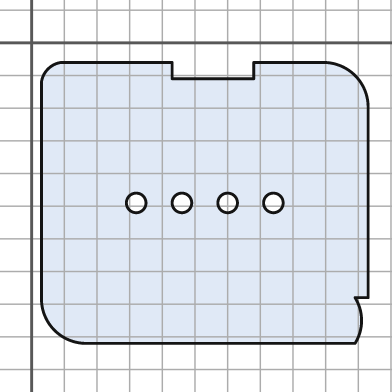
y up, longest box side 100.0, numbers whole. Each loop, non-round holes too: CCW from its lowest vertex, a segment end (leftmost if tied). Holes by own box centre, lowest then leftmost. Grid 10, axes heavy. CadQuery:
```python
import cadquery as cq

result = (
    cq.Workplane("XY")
    .moveTo(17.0, -92.0)
    .lineTo(99.0, -92.0)
    .threePointArc((101.0, -85.0), (99.0, -78.0))
    .lineTo(103.0, -78.0)
    .lineTo(103.0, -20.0)
    .threePointArc((99.0, -10.0), (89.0, -6.0))
    .lineTo(68.0, -6.0)
    .lineTo(68.0, -11.0)
    .lineTo(43.0, -11.0)
    .lineTo(43.0, -6.0)
    .lineTo(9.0, -6.0)
    .threePointArc((5.0, -8.0), (3.0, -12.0))
    .lineTo(3.0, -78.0)
    .threePointArc((7.0, -88.0), (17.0, -92.0))
    .close()
    .moveTo(32.0, -49.0)
    .circle(3.0)
    .moveTo(46.0, -49.0)
    .circle(3.0)
    .moveTo(60.0, -49.0)
    .circle(3.0)
    .moveTo(74.0, -49.0)
    .circle(3.0)
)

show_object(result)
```